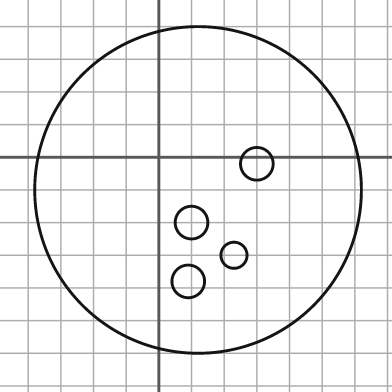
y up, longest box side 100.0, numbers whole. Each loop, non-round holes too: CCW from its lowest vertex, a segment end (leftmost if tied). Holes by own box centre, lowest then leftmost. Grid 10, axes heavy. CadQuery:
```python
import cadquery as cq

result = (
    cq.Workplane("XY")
    .moveTo(12.0, -10.0)
    .circle(50.0)
    .moveTo(9.0, -38.0)
    .circle(5.0)
    .moveTo(23.0, -30.0)
    .circle(4.0)
    .moveTo(10.0, -20.0)
    .circle(5.0)
    .moveTo(30.0, -2.0)
    .circle(5.0)
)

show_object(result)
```